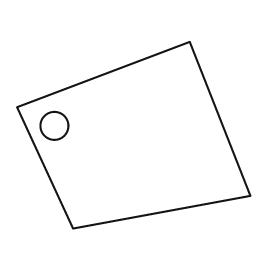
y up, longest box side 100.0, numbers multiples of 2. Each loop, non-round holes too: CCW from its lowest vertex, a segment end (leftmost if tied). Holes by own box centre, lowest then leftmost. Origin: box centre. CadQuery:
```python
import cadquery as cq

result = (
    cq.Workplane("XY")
    .moveTo(-26.0, -40.0)
    .lineTo(50.0, -26.0)
    .lineTo(24.0, 40.0)
    .lineTo(-50.0, 12.0)
    .close()
    .moveTo(-34.0, 4.0)
    .circle(6.0)
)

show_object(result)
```